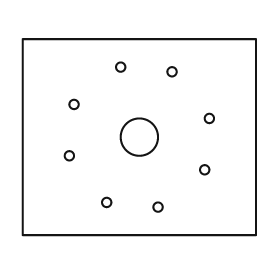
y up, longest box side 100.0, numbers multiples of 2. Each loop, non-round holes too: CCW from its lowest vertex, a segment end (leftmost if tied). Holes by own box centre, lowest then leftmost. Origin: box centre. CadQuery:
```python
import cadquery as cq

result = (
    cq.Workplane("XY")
    .moveTo(-50.0, -42.0)
    .lineTo(50.0, -42.0)
    .lineTo(50.0, 42.0)
    .lineTo(-50.0, 42.0)
    .close()
    .moveTo(8.0, -30.0)
    .circle(2.0)
    .moveTo(-14.0, -28.0)
    .circle(2.0)
    .moveTo(28.0, -14.0)
    .circle(2.0)
    .moveTo(-30.0, -8.0)
    .circle(2.0)
    .moveTo(0.0, 0.0)
    .circle(8.0)
    .moveTo(30.0, 8.0)
    .circle(2.0)
    .moveTo(-28.0, 14.0)
    .circle(2.0)
    .moveTo(14.0, 28.0)
    .circle(2.0)
    .moveTo(-8.0, 30.0)
    .circle(2.0)
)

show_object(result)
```